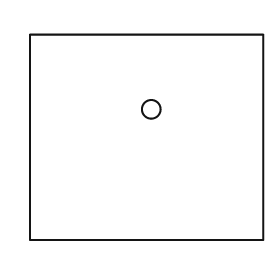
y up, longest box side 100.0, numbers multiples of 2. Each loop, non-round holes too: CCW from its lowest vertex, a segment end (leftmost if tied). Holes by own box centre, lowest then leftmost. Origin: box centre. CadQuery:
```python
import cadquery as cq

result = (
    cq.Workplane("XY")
    .moveTo(-50.0, -44.0)
    .lineTo(50.0, -44.0)
    .lineTo(50.0, 44.0)
    .lineTo(-50.0, 44.0)
    .close()
    .moveTo(2.0, 12.0)
    .circle(4.0)
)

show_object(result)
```